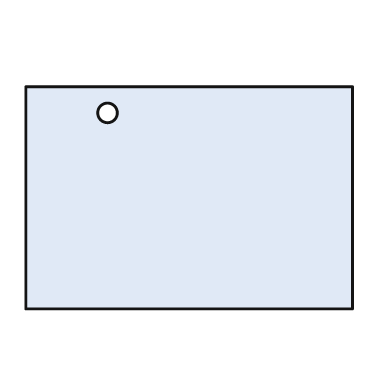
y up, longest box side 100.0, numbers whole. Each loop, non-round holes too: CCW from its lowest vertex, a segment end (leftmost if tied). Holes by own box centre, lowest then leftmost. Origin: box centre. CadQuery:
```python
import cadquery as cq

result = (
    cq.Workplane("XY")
    .moveTo(-50.0, -34.0)
    .lineTo(50.0, -34.0)
    .lineTo(50.0, 34.0)
    .lineTo(-50.0, 34.0)
    .close()
    .moveTo(-25.0, 26.0)
    .circle(3.0)
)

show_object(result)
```